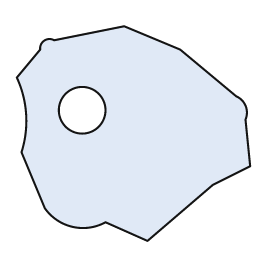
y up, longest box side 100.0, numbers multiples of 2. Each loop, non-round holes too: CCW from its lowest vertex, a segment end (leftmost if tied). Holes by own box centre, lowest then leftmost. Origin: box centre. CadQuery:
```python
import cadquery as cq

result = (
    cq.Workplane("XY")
    .moveTo(6.0, -46.0)
    .lineTo(34.0, -22.0)
    .lineTo(50.0, -14.0)
    .lineTo(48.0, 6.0)
    .threePointArc((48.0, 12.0), (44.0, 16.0))
    .lineTo(20.0, 36.0)
    .lineTo(-4.0, 46.0)
    .lineTo(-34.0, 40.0)
    .threePointArc((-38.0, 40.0), (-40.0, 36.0))
    .lineTo(-50.0, 24.0)
    .threePointArc((-46.0, 8.0), (-48.0, -8.0))
    .lineTo(-38.0, -32.0)
    .threePointArc((-26.0, -40.0), (-12.0, -38.0))
    .close()
    .moveTo(-22.0, 10.0)
    .circle(10.0)
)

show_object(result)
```